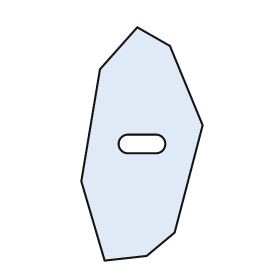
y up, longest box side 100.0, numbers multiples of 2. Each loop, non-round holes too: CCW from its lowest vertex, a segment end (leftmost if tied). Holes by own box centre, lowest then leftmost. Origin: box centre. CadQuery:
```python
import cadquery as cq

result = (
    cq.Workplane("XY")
    .moveTo(-16.0, -50.0)
    .lineTo(2.0, -48.0)
    .lineTo(14.0, -38.0)
    .lineTo(26.0, 8.0)
    .lineTo(12.0, 42.0)
    .lineTo(-2.0, 50.0)
    .lineTo(-18.0, 32.0)
    .lineTo(-26.0, -16.0)
    .close()
    .moveTo(-6.0, -4.0)
    .lineTo(6.0, -4.0)
    .threePointArc((10.0, 0.0), (6.0, 4.0))
    .lineTo(-6.0, 4.0)
    .threePointArc((-10.0, 0.0), (-6.0, -4.0))
    .close()
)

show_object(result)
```